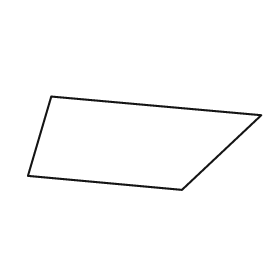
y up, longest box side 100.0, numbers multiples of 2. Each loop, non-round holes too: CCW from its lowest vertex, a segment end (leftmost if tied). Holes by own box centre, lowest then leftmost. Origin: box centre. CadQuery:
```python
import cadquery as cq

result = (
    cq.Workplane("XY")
    .moveTo(16.0, -20.0)
    .lineTo(50.0, 12.0)
    .lineTo(-40.0, 20.0)
    .lineTo(-50.0, -14.0)
    .close()
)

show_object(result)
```